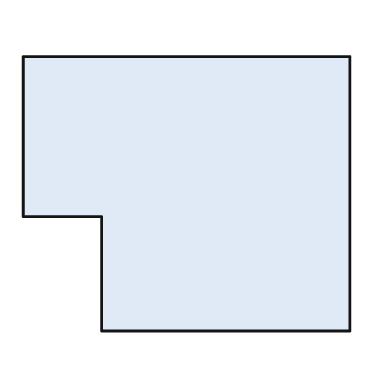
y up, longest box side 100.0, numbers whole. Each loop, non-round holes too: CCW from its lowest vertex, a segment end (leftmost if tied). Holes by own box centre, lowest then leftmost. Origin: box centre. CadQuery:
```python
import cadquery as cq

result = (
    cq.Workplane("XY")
    .moveTo(-26.0, -42.0)
    .lineTo(50.0, -42.0)
    .lineTo(50.0, 42.0)
    .lineTo(-50.0, 42.0)
    .lineTo(-50.0, -7.0)
    .lineTo(-26.0, -7.0)
    .close()
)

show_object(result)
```